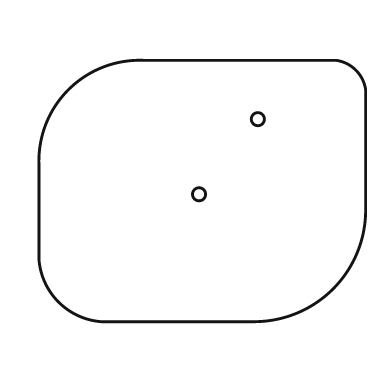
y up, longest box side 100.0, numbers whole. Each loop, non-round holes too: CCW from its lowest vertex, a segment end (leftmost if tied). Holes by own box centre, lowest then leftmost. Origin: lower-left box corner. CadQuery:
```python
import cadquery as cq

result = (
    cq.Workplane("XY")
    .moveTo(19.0, 0.0)
    .lineTo(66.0, 0.0)
    .threePointArc((90.0, 10.0), (100.0, 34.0))
    .lineTo(100.0, 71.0)
    .threePointArc((97.0, 77.0), (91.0, 80.0))
    .lineTo(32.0, 80.0)
    .threePointArc((9.0, 71.0), (0.0, 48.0))
    .lineTo(0.0, 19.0)
    .threePointArc((6.0, 6.0), (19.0, 0.0))
    .close()
    .moveTo(49.0, 39.0)
    .circle(2.0)
    .moveTo(67.0, 62.0)
    .circle(2.0)
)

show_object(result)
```